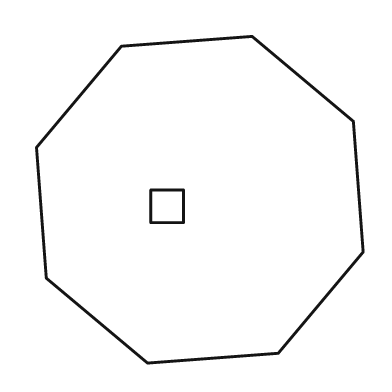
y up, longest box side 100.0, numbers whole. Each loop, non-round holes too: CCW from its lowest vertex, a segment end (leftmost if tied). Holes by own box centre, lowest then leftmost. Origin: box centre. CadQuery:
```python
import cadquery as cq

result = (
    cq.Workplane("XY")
    .moveTo(-16.0, -50.0)
    .lineTo(24.0, -47.0)
    .lineTo(50.0, -16.0)
    .lineTo(47.0, 24.0)
    .lineTo(16.0, 50.0)
    .lineTo(-24.0, 47.0)
    .lineTo(-50.0, 16.0)
    .lineTo(-47.0, -24.0)
    .close()
    .moveTo(-15.0, -7.0)
    .lineTo(-5.0, -7.0)
    .lineTo(-5.0, 3.0)
    .lineTo(-15.0, 3.0)
    .close()
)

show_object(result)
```